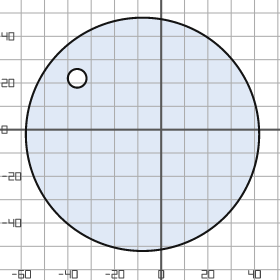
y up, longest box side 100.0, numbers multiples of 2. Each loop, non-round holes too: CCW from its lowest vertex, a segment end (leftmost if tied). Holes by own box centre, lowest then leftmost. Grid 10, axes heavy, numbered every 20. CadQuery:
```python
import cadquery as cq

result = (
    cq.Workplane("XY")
    .moveTo(-8.0, -2.0)
    .circle(50.0)
    .moveTo(-36.0, 22.0)
    .circle(4.0)
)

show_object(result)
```